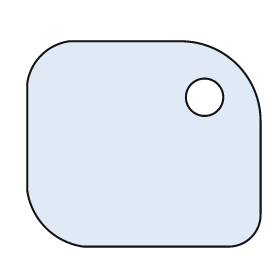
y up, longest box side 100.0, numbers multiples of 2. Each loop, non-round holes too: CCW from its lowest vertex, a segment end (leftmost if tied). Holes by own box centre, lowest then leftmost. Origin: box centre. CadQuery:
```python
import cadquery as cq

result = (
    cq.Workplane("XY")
    .moveTo(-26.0, -44.0)
    .lineTo(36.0, -44.0)
    .threePointArc((46.0, -40.0), (50.0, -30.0))
    .lineTo(50.0, 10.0)
    .threePointArc((40.0, 34.0), (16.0, 44.0))
    .lineTo(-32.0, 44.0)
    .threePointArc((-44.0, 38.0), (-50.0, 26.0))
    .lineTo(-50.0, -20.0)
    .threePointArc((-42.0, -36.0), (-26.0, -44.0))
    .close()
    .moveTo(26.0, 20.0)
    .circle(8.0)
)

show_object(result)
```